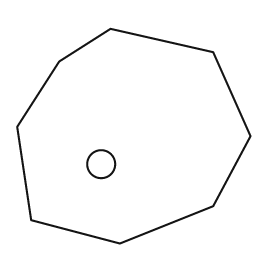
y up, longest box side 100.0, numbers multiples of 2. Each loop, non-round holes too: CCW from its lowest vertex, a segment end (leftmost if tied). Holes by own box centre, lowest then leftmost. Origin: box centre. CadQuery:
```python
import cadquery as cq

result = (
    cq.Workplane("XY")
    .moveTo(-6.0, -46.0)
    .lineTo(34.0, -30.0)
    .lineTo(50.0, 0.0)
    .lineTo(34.0, 36.0)
    .lineTo(-10.0, 46.0)
    .lineTo(-32.0, 32.0)
    .lineTo(-50.0, 4.0)
    .lineTo(-44.0, -36.0)
    .close()
    .moveTo(-14.0, -12.0)
    .circle(6.0)
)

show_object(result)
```